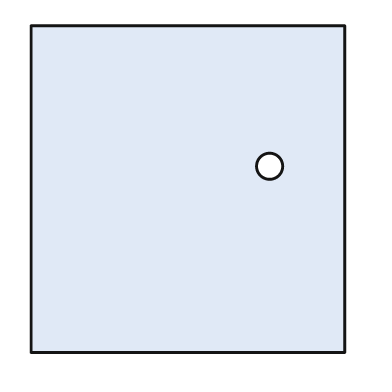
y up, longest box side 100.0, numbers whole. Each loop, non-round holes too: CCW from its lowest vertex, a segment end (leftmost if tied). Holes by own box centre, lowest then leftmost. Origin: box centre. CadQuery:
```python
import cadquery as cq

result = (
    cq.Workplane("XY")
    .moveTo(-48.0, -50.0)
    .lineTo(48.0, -50.0)
    .lineTo(48.0, 50.0)
    .lineTo(-48.0, 50.0)
    .close()
    .moveTo(25.0, 7.0)
    .circle(4.0)
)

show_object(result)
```